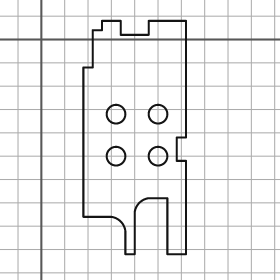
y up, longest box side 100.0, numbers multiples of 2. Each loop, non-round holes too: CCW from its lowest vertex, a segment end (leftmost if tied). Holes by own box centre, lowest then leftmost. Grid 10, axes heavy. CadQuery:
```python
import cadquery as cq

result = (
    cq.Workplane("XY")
    .moveTo(36.0, -92.0)
    .lineTo(40.0, -92.0)
    .lineTo(40.0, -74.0)
    .threePointArc((42.0, -70.0), (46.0, -68.0))
    .lineTo(54.0, -68.0)
    .lineTo(54.0, -92.0)
    .lineTo(62.0, -92.0)
    .lineTo(62.0, -52.0)
    .lineTo(58.0, -52.0)
    .lineTo(58.0, -42.0)
    .lineTo(62.0, -42.0)
    .lineTo(62.0, 8.0)
    .lineTo(46.0, 8.0)
    .lineTo(46.0, 2.0)
    .lineTo(34.0, 2.0)
    .lineTo(34.0, 8.0)
    .lineTo(26.0, 8.0)
    .lineTo(26.0, 4.0)
    .lineTo(22.0, 4.0)
    .lineTo(22.0, -12.0)
    .lineTo(18.0, -12.0)
    .lineTo(18.0, -76.0)
    .lineTo(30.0, -76.0)
    .threePointArc((34.0, -78.0), (36.0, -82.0))
    .close()
    .moveTo(32.0, -50.0)
    .circle(4.0)
    .moveTo(50.0, -50.0)
    .circle(4.0)
    .moveTo(32.0, -32.0)
    .circle(4.0)
    .moveTo(50.0, -32.0)
    .circle(4.0)
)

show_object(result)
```